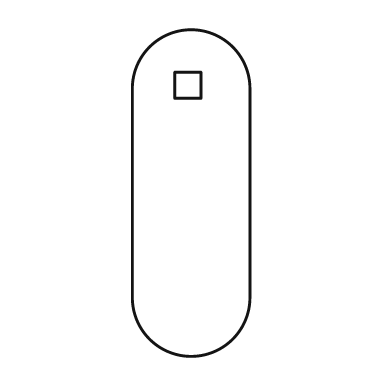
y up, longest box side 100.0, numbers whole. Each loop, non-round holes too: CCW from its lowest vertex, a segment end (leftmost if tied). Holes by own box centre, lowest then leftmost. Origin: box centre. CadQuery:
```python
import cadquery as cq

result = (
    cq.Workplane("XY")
    .moveTo(-18.0, -32.0)
    .threePointArc((0.0, -50.0), (18.0, -32.0))
    .lineTo(18.0, 32.0)
    .threePointArc((0.0, 50.0), (-18.0, 32.0))
    .close()
    .moveTo(-5.0, 29.0)
    .lineTo(3.0, 29.0)
    .lineTo(3.0, 37.0)
    .lineTo(-5.0, 37.0)
    .close()
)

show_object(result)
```